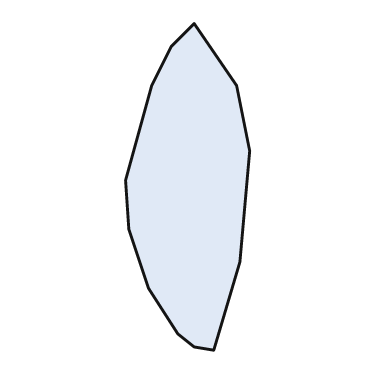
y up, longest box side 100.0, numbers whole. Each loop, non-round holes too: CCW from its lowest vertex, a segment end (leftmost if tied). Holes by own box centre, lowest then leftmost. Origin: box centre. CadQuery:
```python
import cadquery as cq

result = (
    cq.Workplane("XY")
    .moveTo(8.0, -50.0)
    .lineTo(16.0, -23.0)
    .lineTo(19.0, 11.0)
    .lineTo(15.0, 31.0)
    .lineTo(2.0, 50.0)
    .lineTo(-5.0, 43.0)
    .lineTo(-11.0, 31.0)
    .lineTo(-19.0, 2.0)
    .lineTo(-18.0, -13.0)
    .lineTo(-12.0, -31.0)
    .lineTo(-3.0, -45.0)
    .lineTo(2.0, -49.0)
    .close()
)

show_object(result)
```